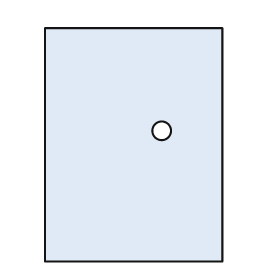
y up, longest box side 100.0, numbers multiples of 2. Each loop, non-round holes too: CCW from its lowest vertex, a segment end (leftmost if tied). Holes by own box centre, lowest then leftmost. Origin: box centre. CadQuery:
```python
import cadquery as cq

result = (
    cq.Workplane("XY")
    .moveTo(-38.0, -50.0)
    .lineTo(38.0, -50.0)
    .lineTo(38.0, 50.0)
    .lineTo(-38.0, 50.0)
    .close()
    .moveTo(12.0, 6.0)
    .circle(4.0)
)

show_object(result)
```